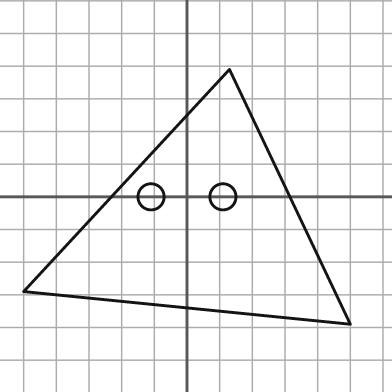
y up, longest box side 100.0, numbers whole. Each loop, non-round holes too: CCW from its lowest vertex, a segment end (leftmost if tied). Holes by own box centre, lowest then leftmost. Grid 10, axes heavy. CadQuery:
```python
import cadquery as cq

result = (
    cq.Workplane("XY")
    .moveTo(50.0, -39.0)
    .lineTo(13.0, 39.0)
    .lineTo(-50.0, -29.0)
    .close()
    .moveTo(-11.0, 0.0)
    .circle(4.0)
    .moveTo(11.0, 0.0)
    .circle(4.0)
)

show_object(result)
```